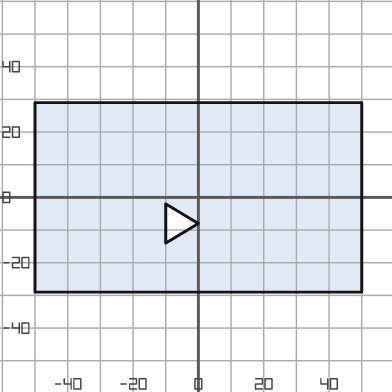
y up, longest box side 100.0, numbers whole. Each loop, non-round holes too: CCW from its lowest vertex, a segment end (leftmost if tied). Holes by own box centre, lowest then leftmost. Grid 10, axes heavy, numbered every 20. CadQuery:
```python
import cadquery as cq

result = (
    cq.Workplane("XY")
    .moveTo(-50.0, -29.0)
    .lineTo(50.0, -29.0)
    .lineTo(50.0, 29.0)
    .lineTo(-50.0, 29.0)
    .close()
    .moveTo(-10.0, -14.0)
    .lineTo(0.0, -8.0)
    .lineTo(-10.0, -2.0)
    .close()
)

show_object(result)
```